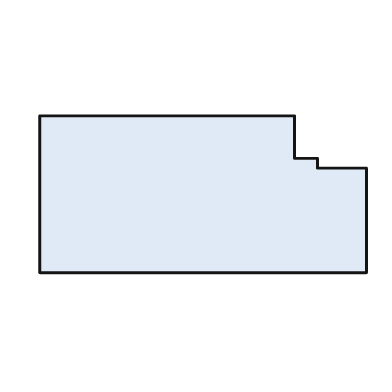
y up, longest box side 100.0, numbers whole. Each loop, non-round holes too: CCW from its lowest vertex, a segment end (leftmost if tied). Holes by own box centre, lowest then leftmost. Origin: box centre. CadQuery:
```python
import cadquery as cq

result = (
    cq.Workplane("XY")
    .moveTo(-50.0, -24.0)
    .lineTo(50.0, -24.0)
    .lineTo(50.0, 8.0)
    .lineTo(35.0, 8.0)
    .lineTo(35.0, 11.0)
    .lineTo(28.0, 11.0)
    .lineTo(28.0, 24.0)
    .lineTo(-50.0, 24.0)
    .close()
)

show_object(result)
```